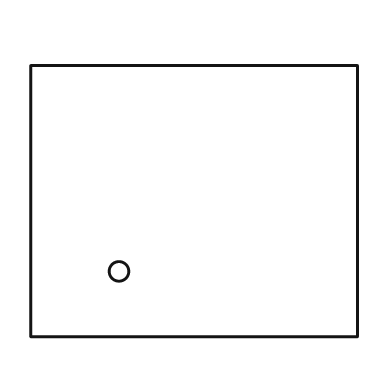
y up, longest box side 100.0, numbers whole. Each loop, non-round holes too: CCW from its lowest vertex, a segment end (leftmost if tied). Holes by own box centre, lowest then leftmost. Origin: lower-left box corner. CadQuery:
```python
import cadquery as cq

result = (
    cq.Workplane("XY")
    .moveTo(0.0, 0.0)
    .lineTo(100.0, 0.0)
    .lineTo(100.0, 83.0)
    .lineTo(0.0, 83.0)
    .close()
    .moveTo(27.0, 20.0)
    .circle(3.0)
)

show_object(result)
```